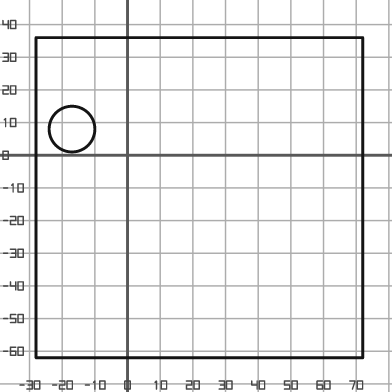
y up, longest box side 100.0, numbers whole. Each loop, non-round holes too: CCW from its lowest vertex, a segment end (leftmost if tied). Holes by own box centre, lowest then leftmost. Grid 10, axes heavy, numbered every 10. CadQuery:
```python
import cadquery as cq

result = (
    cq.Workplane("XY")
    .moveTo(-28.0, -62.0)
    .lineTo(72.0, -62.0)
    .lineTo(72.0, 36.0)
    .lineTo(-28.0, 36.0)
    .close()
    .moveTo(-17.0, 8.0)
    .circle(7.0)
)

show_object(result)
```